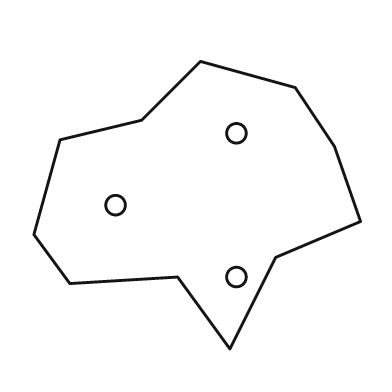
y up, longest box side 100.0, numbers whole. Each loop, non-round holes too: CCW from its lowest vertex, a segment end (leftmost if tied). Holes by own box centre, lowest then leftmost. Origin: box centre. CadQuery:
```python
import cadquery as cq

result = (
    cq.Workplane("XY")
    .moveTo(10.0, -44.0)
    .lineTo(24.0, -16.0)
    .lineTo(50.0, -5.0)
    .lineTo(42.0, 18.0)
    .lineTo(30.0, 36.0)
    .lineTo(1.0, 44.0)
    .lineTo(-17.0, 26.0)
    .lineTo(-42.0, 20.0)
    .lineTo(-50.0, -9.0)
    .lineTo(-39.0, -24.0)
    .lineTo(-6.0, -22.0)
    .close()
    .moveTo(12.0, -22.0)
    .circle(3.0)
    .moveTo(-25.0, 0.0)
    .circle(3.0)
    .moveTo(12.0, 22.0)
    .circle(3.0)
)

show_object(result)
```